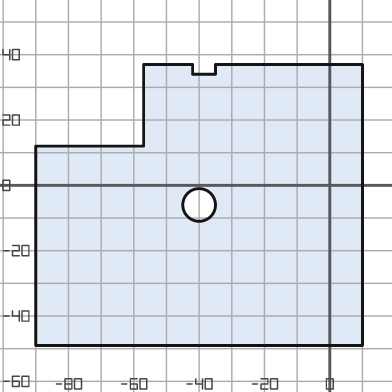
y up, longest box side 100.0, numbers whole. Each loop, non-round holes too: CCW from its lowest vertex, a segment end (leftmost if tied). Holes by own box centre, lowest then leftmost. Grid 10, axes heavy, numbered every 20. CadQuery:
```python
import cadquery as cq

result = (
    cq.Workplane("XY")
    .moveTo(-90.0, -49.0)
    .lineTo(10.0, -49.0)
    .lineTo(10.0, 37.0)
    .lineTo(-35.0, 37.0)
    .lineTo(-35.0, 34.0)
    .lineTo(-42.0, 34.0)
    .lineTo(-42.0, 37.0)
    .lineTo(-57.0, 37.0)
    .lineTo(-57.0, 12.0)
    .lineTo(-90.0, 12.0)
    .close()
    .moveTo(-40.0, -6.0)
    .circle(5.0)
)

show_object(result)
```